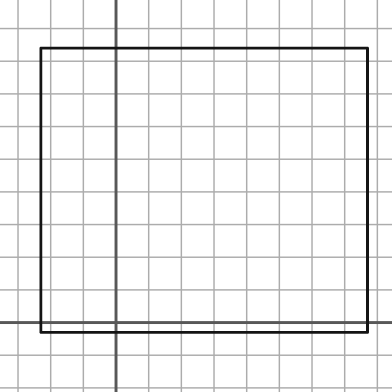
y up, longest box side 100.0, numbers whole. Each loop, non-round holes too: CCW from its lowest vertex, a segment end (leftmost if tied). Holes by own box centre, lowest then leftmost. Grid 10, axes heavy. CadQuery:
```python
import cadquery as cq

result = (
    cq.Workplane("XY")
    .moveTo(-23.0, -3.0)
    .lineTo(77.0, -3.0)
    .lineTo(77.0, 84.0)
    .lineTo(-23.0, 84.0)
    .close()
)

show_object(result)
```